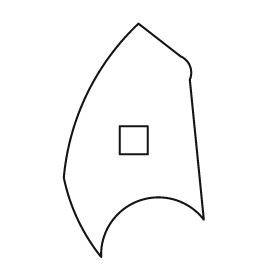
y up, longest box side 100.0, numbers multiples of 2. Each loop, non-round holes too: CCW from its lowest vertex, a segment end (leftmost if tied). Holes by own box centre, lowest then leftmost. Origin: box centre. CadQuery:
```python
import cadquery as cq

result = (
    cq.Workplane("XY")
    .moveTo(-14.0, -50.0)
    .threePointArc((2.0, -26.0), (30.0, -34.0))
    .lineTo(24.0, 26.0)
    .threePointArc((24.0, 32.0), (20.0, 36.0))
    .lineTo(2.0, 50.0)
    .threePointArc((-20.0, 20.0), (-30.0, -16.0))
    .threePointArc((-24.0, -34.0), (-14.0, -50.0))
    .close()
    .moveTo(-6.0, -6.0)
    .lineTo(6.0, -6.0)
    .lineTo(6.0, 6.0)
    .lineTo(-6.0, 6.0)
    .close()
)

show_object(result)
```